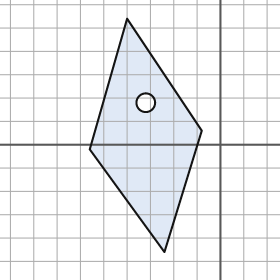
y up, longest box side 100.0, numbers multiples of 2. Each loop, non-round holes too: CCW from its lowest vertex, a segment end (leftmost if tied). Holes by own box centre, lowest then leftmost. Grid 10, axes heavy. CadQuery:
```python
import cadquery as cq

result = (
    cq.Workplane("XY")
    .moveTo(-24.0, -46.0)
    .lineTo(-8.0, 6.0)
    .lineTo(-40.0, 54.0)
    .lineTo(-56.0, -2.0)
    .close()
    .moveTo(-32.0, 18.0)
    .circle(4.0)
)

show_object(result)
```